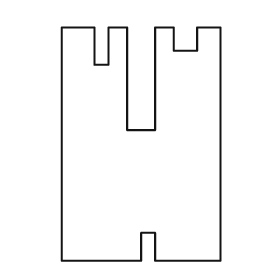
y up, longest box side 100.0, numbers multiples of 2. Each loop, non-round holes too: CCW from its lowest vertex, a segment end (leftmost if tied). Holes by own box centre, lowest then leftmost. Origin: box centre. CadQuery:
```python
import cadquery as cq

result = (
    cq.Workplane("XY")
    .moveTo(-34.0, -50.0)
    .lineTo(0.0, -50.0)
    .lineTo(0.0, -38.0)
    .lineTo(6.0, -38.0)
    .lineTo(6.0, -50.0)
    .lineTo(34.0, -50.0)
    .lineTo(34.0, 50.0)
    .lineTo(24.0, 50.0)
    .lineTo(24.0, 40.0)
    .lineTo(14.0, 40.0)
    .lineTo(14.0, 50.0)
    .lineTo(6.0, 50.0)
    .lineTo(6.0, 6.0)
    .lineTo(-6.0, 6.0)
    .lineTo(-6.0, 50.0)
    .lineTo(-14.0, 50.0)
    .lineTo(-14.0, 34.0)
    .lineTo(-20.0, 34.0)
    .lineTo(-20.0, 50.0)
    .lineTo(-34.0, 50.0)
    .close()
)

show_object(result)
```